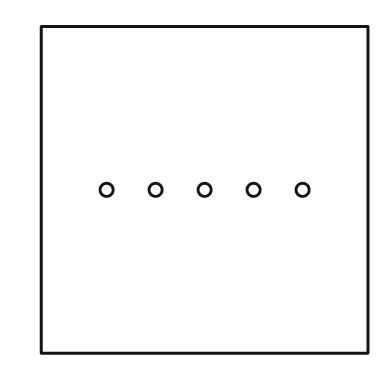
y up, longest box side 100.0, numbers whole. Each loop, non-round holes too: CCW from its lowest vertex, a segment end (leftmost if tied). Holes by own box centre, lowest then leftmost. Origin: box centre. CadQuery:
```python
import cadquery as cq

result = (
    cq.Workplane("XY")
    .moveTo(-50.0, -50.0)
    .lineTo(50.0, -50.0)
    .lineTo(50.0, 50.0)
    .lineTo(-50.0, 50.0)
    .close()
    .moveTo(-30.0, 0.0)
    .circle(2.0)
    .moveTo(-15.0, 0.0)
    .circle(2.0)
    .moveTo(0.0, 0.0)
    .circle(2.0)
    .moveTo(15.0, 0.0)
    .circle(2.0)
    .moveTo(30.0, 0.0)
    .circle(2.0)
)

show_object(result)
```